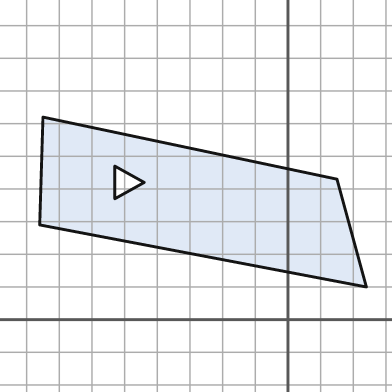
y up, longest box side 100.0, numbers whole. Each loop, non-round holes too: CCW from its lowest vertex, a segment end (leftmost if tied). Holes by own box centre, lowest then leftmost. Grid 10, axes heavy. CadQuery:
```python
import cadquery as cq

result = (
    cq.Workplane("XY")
    .moveTo(24.0, 10.0)
    .lineTo(15.0, 43.0)
    .lineTo(-75.0, 62.0)
    .lineTo(-76.0, 29.0)
    .close()
    .moveTo(-53.0, 37.0)
    .lineTo(-44.0, 42.0)
    .lineTo(-53.0, 47.0)
    .close()
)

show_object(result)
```